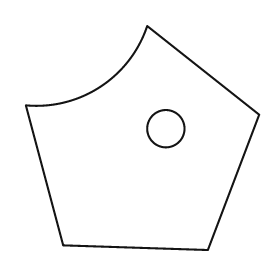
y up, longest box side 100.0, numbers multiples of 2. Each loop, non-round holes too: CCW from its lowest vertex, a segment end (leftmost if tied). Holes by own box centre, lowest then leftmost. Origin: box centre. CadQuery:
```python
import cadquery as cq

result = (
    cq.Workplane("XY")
    .moveTo(28.0, -48.0)
    .lineTo(50.0, 10.0)
    .lineTo(2.0, 48.0)
    .threePointArc((-18.0, 22.0), (-50.0, 14.0))
    .lineTo(-34.0, -46.0)
    .close()
    .moveTo(10.0, 4.0)
    .circle(8.0)
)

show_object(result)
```